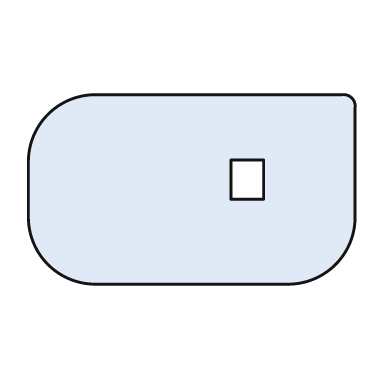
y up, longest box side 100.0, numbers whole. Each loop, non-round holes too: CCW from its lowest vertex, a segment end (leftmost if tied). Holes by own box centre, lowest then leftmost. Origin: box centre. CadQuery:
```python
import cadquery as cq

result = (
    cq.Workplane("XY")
    .moveTo(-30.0, -29.0)
    .lineTo(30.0, -29.0)
    .threePointArc((44.0, -23.0), (50.0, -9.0))
    .lineTo(50.0, 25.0)
    .threePointArc((49.0, 28.0), (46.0, 29.0))
    .lineTo(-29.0, 29.0)
    .threePointArc((-44.0, 23.0), (-50.0, 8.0))
    .lineTo(-50.0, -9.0)
    .threePointArc((-44.0, -23.0), (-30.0, -29.0))
    .close()
    .moveTo(12.0, -3.0)
    .lineTo(22.0, -3.0)
    .lineTo(22.0, 9.0)
    .lineTo(12.0, 9.0)
    .close()
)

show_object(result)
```